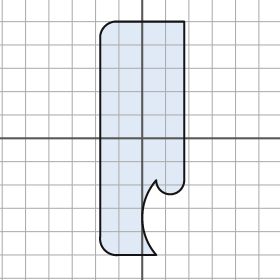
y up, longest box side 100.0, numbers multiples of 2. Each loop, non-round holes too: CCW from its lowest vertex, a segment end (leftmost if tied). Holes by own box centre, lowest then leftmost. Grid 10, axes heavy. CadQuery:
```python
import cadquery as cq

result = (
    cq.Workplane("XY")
    .moveTo(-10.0, -50.0)
    .lineTo(6.0, -50.0)
    .threePointArc((0.0, -34.0), (6.0, -18.0))
    .threePointArc((12.0, -24.0), (18.0, -18.0))
    .lineTo(18.0, 50.0)
    .lineTo(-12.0, 50.0)
    .threePointArc((-16.0, 48.0), (-18.0, 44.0))
    .lineTo(-18.0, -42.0)
    .threePointArc((-16.0, -48.0), (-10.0, -50.0))
    .close()
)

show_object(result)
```